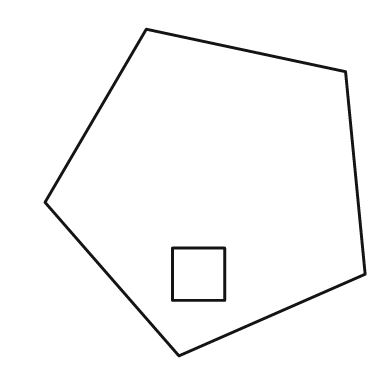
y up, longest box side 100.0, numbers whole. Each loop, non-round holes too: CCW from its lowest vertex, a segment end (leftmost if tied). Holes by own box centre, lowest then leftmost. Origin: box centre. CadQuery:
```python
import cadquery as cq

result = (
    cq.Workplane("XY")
    .moveTo(-8.0, -50.0)
    .lineTo(49.0, -25.0)
    .lineTo(43.0, 37.0)
    .lineTo(-18.0, 50.0)
    .lineTo(-49.0, -3.0)
    .close()
    .moveTo(-10.0, -33.0)
    .lineTo(6.0, -33.0)
    .lineTo(6.0, -17.0)
    .lineTo(-10.0, -17.0)
    .close()
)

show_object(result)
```